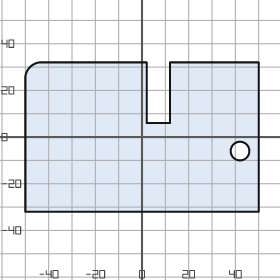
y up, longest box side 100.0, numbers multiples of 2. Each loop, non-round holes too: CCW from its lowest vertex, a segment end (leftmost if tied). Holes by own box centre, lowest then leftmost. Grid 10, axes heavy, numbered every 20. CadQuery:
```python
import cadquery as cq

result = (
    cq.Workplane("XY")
    .moveTo(-50.0, -32.0)
    .lineTo(50.0, -32.0)
    .lineTo(50.0, 32.0)
    .lineTo(12.0, 32.0)
    .lineTo(12.0, 6.0)
    .lineTo(2.0, 6.0)
    .lineTo(2.0, 32.0)
    .lineTo(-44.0, 32.0)
    .threePointArc((-48.0, 30.0), (-50.0, 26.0))
    .close()
    .moveTo(42.0, -6.0)
    .circle(4.0)
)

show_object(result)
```